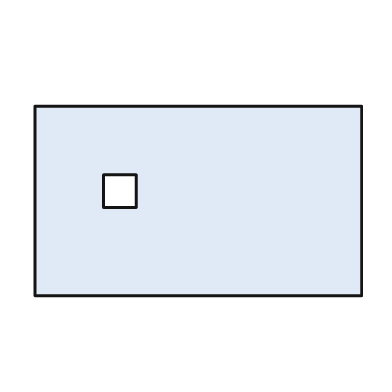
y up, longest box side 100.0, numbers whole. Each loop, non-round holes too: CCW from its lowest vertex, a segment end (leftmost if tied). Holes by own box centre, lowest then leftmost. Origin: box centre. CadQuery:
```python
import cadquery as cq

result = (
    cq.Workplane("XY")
    .moveTo(-50.0, -29.0)
    .lineTo(50.0, -29.0)
    .lineTo(50.0, 29.0)
    .lineTo(-50.0, 29.0)
    .close()
    .moveTo(-29.0, -2.0)
    .lineTo(-19.0, -2.0)
    .lineTo(-19.0, 8.0)
    .lineTo(-29.0, 8.0)
    .close()
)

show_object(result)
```